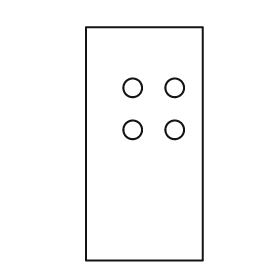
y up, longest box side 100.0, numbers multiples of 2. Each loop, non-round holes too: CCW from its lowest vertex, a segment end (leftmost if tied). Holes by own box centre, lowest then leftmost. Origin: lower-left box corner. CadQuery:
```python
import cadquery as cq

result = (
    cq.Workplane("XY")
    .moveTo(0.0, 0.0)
    .lineTo(50.0, 0.0)
    .lineTo(50.0, 100.0)
    .lineTo(0.0, 100.0)
    .close()
    .moveTo(20.0, 56.0)
    .circle(4.0)
    .moveTo(38.0, 56.0)
    .circle(4.0)
    .moveTo(20.0, 74.0)
    .circle(4.0)
    .moveTo(38.0, 74.0)
    .circle(4.0)
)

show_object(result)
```